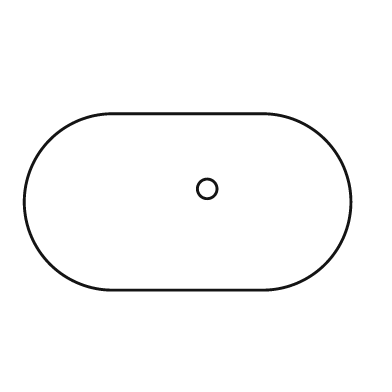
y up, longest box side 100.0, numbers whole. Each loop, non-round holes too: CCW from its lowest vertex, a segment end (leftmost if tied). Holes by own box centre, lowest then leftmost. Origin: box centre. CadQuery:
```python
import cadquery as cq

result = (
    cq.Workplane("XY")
    .moveTo(-23.0, -27.0)
    .lineTo(23.0, -27.0)
    .threePointArc((50.0, 0.0), (23.0, 27.0))
    .lineTo(-23.0, 27.0)
    .threePointArc((-50.0, 0.0), (-23.0, -27.0))
    .close()
    .moveTo(6.0, 4.0)
    .circle(3.0)
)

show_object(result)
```